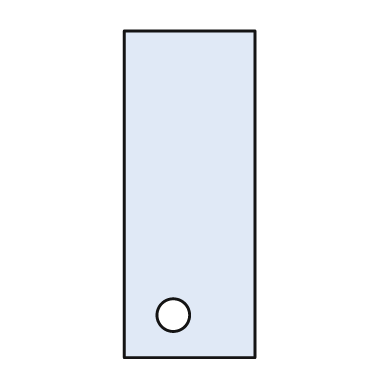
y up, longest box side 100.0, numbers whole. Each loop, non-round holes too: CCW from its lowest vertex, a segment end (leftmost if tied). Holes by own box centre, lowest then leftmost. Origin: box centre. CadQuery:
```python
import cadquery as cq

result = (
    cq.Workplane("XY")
    .moveTo(-20.0, -50.0)
    .lineTo(20.0, -50.0)
    .lineTo(20.0, 50.0)
    .lineTo(-20.0, 50.0)
    .close()
    .moveTo(-5.0, -37.0)
    .circle(5.0)
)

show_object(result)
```